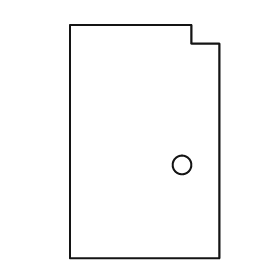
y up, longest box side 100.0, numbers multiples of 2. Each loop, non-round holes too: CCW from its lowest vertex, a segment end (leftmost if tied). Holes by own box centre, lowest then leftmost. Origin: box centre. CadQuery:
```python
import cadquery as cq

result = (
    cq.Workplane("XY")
    .moveTo(-32.0, -50.0)
    .lineTo(32.0, -50.0)
    .lineTo(32.0, 42.0)
    .lineTo(20.0, 42.0)
    .lineTo(20.0, 50.0)
    .lineTo(-32.0, 50.0)
    .close()
    .moveTo(16.0, -10.0)
    .circle(4.0)
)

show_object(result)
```